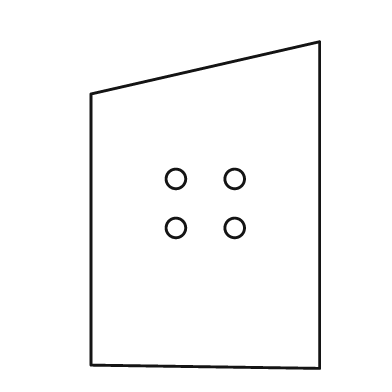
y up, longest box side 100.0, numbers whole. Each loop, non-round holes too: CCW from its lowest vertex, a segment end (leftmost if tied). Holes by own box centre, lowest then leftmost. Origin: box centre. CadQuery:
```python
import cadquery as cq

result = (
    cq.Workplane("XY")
    .moveTo(35.0, -50.0)
    .lineTo(35.0, 50.0)
    .lineTo(-35.0, 34.0)
    .lineTo(-35.0, -49.0)
    .close()
    .moveTo(-9.0, -7.0)
    .circle(3.0)
    .moveTo(9.0, -7.0)
    .circle(3.0)
    .moveTo(-9.0, 8.0)
    .circle(3.0)
    .moveTo(9.0, 8.0)
    .circle(3.0)
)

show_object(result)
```